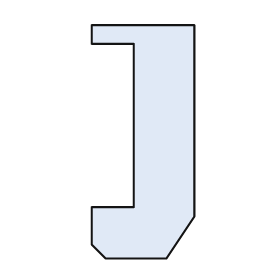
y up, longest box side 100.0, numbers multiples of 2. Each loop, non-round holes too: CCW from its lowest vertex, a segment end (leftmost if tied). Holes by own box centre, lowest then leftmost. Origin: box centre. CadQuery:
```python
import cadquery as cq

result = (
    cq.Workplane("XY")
    .moveTo(-16.0, -50.0)
    .lineTo(10.0, -50.0)
    .lineTo(22.0, -32.0)
    .lineTo(22.0, 50.0)
    .lineTo(-22.0, 50.0)
    .lineTo(-22.0, 42.0)
    .lineTo(-4.0, 42.0)
    .lineTo(-4.0, -28.0)
    .lineTo(-22.0, -28.0)
    .lineTo(-22.0, -44.0)
    .close()
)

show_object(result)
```